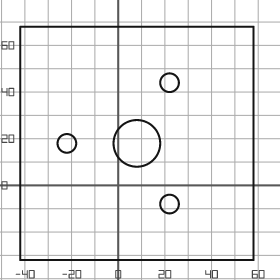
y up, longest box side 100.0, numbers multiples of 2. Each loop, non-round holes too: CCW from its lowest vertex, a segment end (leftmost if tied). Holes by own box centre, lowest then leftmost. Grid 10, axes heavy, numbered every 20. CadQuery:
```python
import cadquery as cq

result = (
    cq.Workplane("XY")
    .moveTo(-42.0, -32.0)
    .lineTo(58.0, -32.0)
    .lineTo(58.0, 68.0)
    .lineTo(-42.0, 68.0)
    .close()
    .moveTo(22.0, -8.0)
    .circle(4.0)
    .moveTo(-22.0, 18.0)
    .circle(4.0)
    .moveTo(8.0, 18.0)
    .circle(10.0)
    .moveTo(22.0, 44.0)
    .circle(4.0)
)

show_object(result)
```